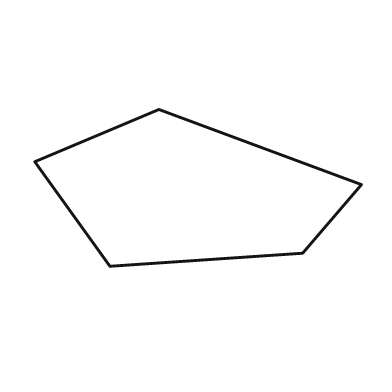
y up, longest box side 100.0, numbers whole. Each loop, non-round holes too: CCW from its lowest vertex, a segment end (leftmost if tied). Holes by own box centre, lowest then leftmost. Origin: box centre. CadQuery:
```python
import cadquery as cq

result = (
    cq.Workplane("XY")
    .moveTo(-27.0, -24.0)
    .lineTo(32.0, -20.0)
    .lineTo(50.0, 1.0)
    .lineTo(-12.0, 24.0)
    .lineTo(-50.0, 8.0)
    .close()
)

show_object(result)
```